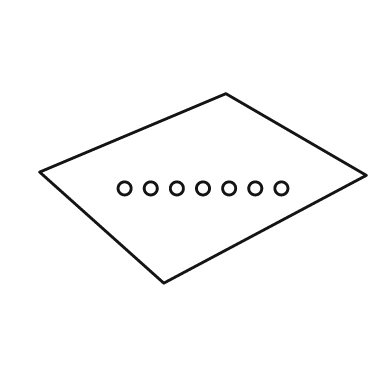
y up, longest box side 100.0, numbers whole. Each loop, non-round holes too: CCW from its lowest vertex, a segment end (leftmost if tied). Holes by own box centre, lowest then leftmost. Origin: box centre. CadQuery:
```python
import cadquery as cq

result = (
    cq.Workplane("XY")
    .moveTo(-12.0, -29.0)
    .lineTo(50.0, 4.0)
    .lineTo(7.0, 29.0)
    .lineTo(-50.0, 5.0)
    .close()
    .moveTo(-24.0, 0.0)
    .circle(2.0)
    .moveTo(-16.0, 0.0)
    .circle(2.0)
    .moveTo(-8.0, 0.0)
    .circle(2.0)
    .moveTo(0.0, 0.0)
    .circle(2.0)
    .moveTo(8.0, 0.0)
    .circle(2.0)
    .moveTo(16.0, 0.0)
    .circle(2.0)
    .moveTo(24.0, 0.0)
    .circle(2.0)
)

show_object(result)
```